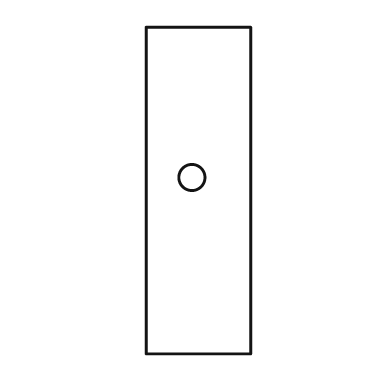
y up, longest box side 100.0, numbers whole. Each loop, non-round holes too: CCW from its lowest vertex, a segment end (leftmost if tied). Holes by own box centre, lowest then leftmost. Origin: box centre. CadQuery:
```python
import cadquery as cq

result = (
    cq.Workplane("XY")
    .moveTo(-16.0, -50.0)
    .lineTo(16.0, -50.0)
    .lineTo(16.0, 50.0)
    .lineTo(-16.0, 50.0)
    .close()
    .moveTo(-2.0, 4.0)
    .circle(4.0)
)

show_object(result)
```